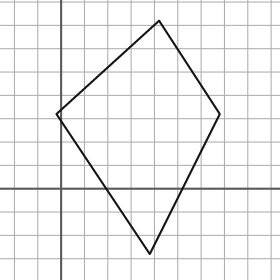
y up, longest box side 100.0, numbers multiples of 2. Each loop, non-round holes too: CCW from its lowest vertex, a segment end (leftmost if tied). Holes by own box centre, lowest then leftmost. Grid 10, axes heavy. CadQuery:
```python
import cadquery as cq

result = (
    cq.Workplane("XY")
    .moveTo(38.0, -28.0)
    .lineTo(68.0, 32.0)
    .lineTo(42.0, 72.0)
    .lineTo(-2.0, 32.0)
    .close()
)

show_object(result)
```